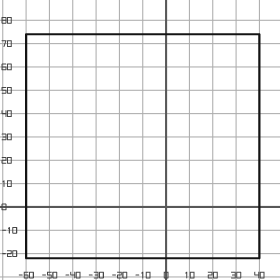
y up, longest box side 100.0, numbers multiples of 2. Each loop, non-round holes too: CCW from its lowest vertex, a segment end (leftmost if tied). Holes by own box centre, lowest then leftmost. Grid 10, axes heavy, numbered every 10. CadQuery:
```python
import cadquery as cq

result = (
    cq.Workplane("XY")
    .moveTo(-60.0, -22.0)
    .lineTo(40.0, -22.0)
    .lineTo(40.0, 74.0)
    .lineTo(-60.0, 74.0)
    .close()
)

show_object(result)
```